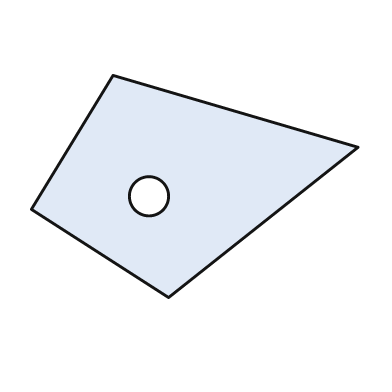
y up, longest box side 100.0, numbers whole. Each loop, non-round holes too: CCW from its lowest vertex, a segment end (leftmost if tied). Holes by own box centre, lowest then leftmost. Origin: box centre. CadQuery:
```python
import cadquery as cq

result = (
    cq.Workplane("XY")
    .moveTo(-8.0, -34.0)
    .lineTo(50.0, 12.0)
    .lineTo(-25.0, 34.0)
    .lineTo(-50.0, -7.0)
    .close()
    .moveTo(-14.0, -3.0)
    .circle(6.0)
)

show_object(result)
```